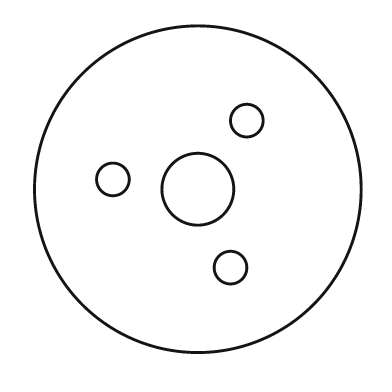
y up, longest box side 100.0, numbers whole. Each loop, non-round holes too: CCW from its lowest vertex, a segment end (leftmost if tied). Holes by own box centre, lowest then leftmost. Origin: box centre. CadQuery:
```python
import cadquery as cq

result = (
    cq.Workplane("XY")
    .moveTo(0.0, 0.0)
    .circle(50.0)
    .moveTo(10.0, -24.0)
    .circle(5.0)
    .moveTo(0.0, 0.0)
    .circle(11.0)
    .moveTo(-26.0, 3.0)
    .circle(5.0)
    .moveTo(15.0, 21.0)
    .circle(5.0)
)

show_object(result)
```